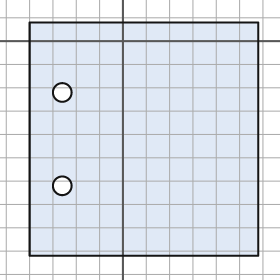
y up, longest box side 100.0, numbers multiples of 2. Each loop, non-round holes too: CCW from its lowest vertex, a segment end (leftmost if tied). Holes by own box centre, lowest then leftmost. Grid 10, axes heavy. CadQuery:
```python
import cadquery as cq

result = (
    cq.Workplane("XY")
    .moveTo(-40.0, -92.0)
    .lineTo(58.0, -92.0)
    .lineTo(58.0, 8.0)
    .lineTo(-40.0, 8.0)
    .close()
    .moveTo(-26.0, -62.0)
    .circle(4.0)
    .moveTo(-26.0, -22.0)
    .circle(4.0)
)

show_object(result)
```